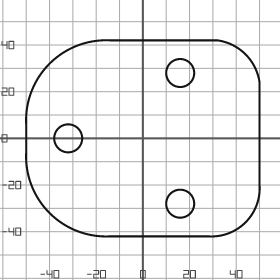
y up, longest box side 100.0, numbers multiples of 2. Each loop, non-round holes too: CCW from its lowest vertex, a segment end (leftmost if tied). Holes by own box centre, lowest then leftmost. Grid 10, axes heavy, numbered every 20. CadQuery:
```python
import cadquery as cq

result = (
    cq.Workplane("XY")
    .moveTo(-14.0, -42.0)
    .lineTo(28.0, -42.0)
    .threePointArc((44.0, -36.0), (50.0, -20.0))
    .lineTo(50.0, 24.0)
    .threePointArc((44.0, 36.0), (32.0, 42.0))
    .lineTo(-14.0, 42.0)
    .threePointArc((-40.0, 32.0), (-50.0, 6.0))
    .lineTo(-50.0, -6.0)
    .threePointArc((-40.0, -32.0), (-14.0, -42.0))
    .close()
    .moveTo(16.0, -28.0)
    .circle(6.0)
    .moveTo(-32.0, 0.0)
    .circle(6.0)
    .moveTo(16.0, 28.0)
    .circle(6.0)
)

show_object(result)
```